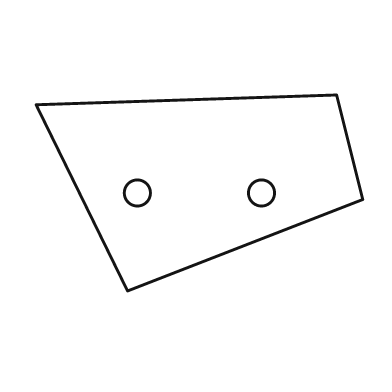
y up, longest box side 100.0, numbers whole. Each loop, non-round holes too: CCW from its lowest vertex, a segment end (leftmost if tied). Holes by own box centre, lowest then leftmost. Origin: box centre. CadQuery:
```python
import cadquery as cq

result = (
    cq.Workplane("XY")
    .moveTo(-22.0, -30.0)
    .lineTo(50.0, -2.0)
    .lineTo(42.0, 30.0)
    .lineTo(-50.0, 27.0)
    .close()
    .moveTo(-19.0, 0.0)
    .circle(4.0)
    .moveTo(19.0, 0.0)
    .circle(4.0)
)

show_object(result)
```